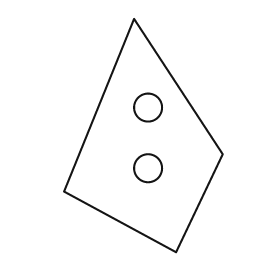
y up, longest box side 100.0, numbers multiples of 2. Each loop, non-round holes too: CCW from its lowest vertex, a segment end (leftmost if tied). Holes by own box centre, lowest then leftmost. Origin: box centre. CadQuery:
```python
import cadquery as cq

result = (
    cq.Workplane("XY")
    .moveTo(14.0, -50.0)
    .lineTo(34.0, -8.0)
    .lineTo(-4.0, 50.0)
    .lineTo(-34.0, -24.0)
    .close()
    .moveTo(2.0, -14.0)
    .circle(6.0)
    .moveTo(2.0, 12.0)
    .circle(6.0)
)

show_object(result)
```